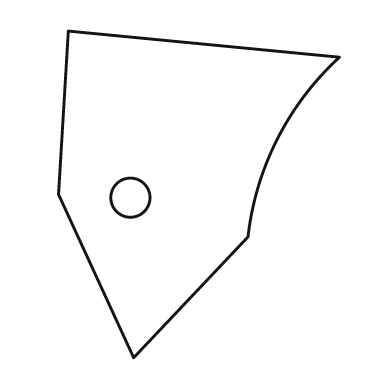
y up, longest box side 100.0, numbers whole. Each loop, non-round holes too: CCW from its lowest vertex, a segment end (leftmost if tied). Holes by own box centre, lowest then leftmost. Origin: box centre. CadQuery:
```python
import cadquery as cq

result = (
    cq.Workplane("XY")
    .moveTo(-20.0, -50.0)
    .lineTo(15.0, -13.0)
    .threePointArc((24.0, 17.0), (43.0, 42.0))
    .lineTo(-40.0, 50.0)
    .lineTo(-43.0, 0.0)
    .close()
    .moveTo(-21.0, -1.0)
    .circle(6.0)
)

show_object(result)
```